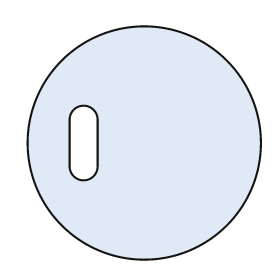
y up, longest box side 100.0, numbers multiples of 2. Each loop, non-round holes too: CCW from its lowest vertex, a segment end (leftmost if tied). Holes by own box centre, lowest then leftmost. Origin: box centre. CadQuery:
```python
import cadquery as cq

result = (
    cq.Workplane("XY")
    .moveTo(0.0, 0.0)
    .circle(50.0)
    .moveTo(-32.0, -10.0)
    .threePointArc((-26.0, -16.0), (-20.0, -10.0))
    .lineTo(-20.0, 10.0)
    .threePointArc((-26.0, 16.0), (-32.0, 10.0))
    .close()
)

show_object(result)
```